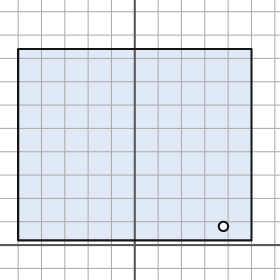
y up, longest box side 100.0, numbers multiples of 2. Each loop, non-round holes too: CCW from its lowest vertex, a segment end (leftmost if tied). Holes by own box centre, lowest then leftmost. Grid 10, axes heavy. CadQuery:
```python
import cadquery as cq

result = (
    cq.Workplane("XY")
    .moveTo(-50.0, 2.0)
    .lineTo(50.0, 2.0)
    .lineTo(50.0, 84.0)
    .lineTo(-50.0, 84.0)
    .close()
    .moveTo(38.0, 8.0)
    .circle(2.0)
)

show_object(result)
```